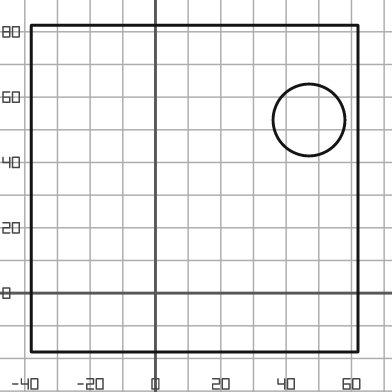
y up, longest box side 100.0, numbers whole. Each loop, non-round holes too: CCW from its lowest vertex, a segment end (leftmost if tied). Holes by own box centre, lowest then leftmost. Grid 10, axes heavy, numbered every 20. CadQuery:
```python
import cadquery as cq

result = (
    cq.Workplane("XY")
    .moveTo(-38.0, -18.0)
    .lineTo(62.0, -18.0)
    .lineTo(62.0, 82.0)
    .lineTo(-38.0, 82.0)
    .close()
    .moveTo(47.0, 53.0)
    .circle(11.0)
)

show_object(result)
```